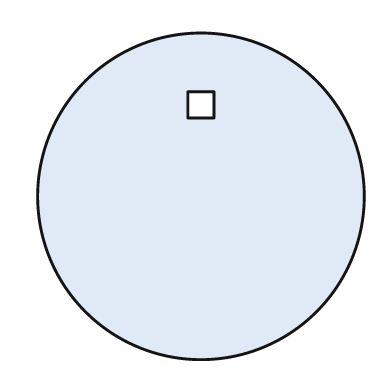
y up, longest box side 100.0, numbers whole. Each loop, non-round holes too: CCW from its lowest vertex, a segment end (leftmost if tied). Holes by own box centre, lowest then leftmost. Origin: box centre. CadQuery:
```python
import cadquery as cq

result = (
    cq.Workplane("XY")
    .moveTo(0.0, 0.0)
    .circle(50.0)
    .moveTo(-4.0, 24.0)
    .lineTo(4.0, 24.0)
    .lineTo(4.0, 32.0)
    .lineTo(-4.0, 32.0)
    .close()
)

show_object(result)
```